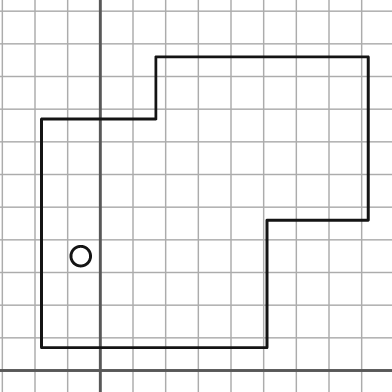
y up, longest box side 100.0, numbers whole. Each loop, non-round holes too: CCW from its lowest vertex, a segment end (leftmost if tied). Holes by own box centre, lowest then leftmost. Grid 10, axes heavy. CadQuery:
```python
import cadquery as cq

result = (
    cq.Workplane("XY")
    .moveTo(-18.0, 7.0)
    .lineTo(51.0, 7.0)
    .lineTo(51.0, 46.0)
    .lineTo(82.0, 46.0)
    .lineTo(82.0, 96.0)
    .lineTo(17.0, 96.0)
    .lineTo(17.0, 77.0)
    .lineTo(-18.0, 77.0)
    .close()
    .moveTo(-6.0, 35.0)
    .circle(3.0)
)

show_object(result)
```